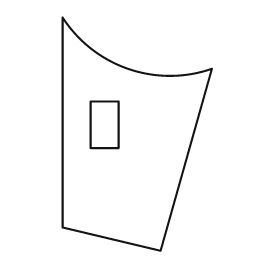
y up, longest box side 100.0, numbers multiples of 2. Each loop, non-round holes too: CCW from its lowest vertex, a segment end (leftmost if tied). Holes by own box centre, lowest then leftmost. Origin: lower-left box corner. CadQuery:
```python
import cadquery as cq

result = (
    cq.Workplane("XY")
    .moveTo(42.0, 0.0)
    .lineTo(64.0, 78.0)
    .threePointArc((28.0, 78.0), (0.0, 100.0))
    .lineTo(0.0, 10.0)
    .close()
    .moveTo(12.0, 44.0)
    .lineTo(24.0, 44.0)
    .lineTo(24.0, 64.0)
    .lineTo(12.0, 64.0)
    .close()
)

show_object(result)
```